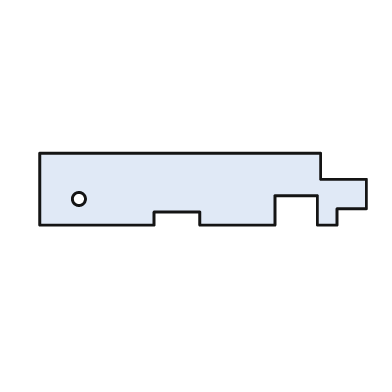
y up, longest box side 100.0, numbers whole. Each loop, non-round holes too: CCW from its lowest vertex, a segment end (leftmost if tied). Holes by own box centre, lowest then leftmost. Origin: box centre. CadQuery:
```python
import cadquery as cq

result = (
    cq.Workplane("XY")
    .moveTo(-50.0, -11.0)
    .lineTo(-15.0, -11.0)
    .lineTo(-15.0, -7.0)
    .lineTo(-1.0, -7.0)
    .lineTo(-1.0, -11.0)
    .lineTo(22.0, -11.0)
    .lineTo(22.0, -2.0)
    .lineTo(35.0, -2.0)
    .lineTo(35.0, -11.0)
    .lineTo(41.0, -11.0)
    .lineTo(41.0, -6.0)
    .lineTo(50.0, -6.0)
    .lineTo(50.0, 3.0)
    .lineTo(36.0, 3.0)
    .lineTo(36.0, 11.0)
    .lineTo(-50.0, 11.0)
    .close()
    .moveTo(-38.0, -3.0)
    .circle(2.0)
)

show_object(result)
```